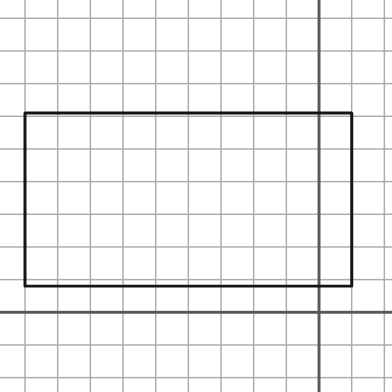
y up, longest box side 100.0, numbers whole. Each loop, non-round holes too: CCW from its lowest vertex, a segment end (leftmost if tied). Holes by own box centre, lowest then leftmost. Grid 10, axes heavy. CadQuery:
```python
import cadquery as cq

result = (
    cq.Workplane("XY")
    .moveTo(-90.0, 8.0)
    .lineTo(10.0, 8.0)
    .lineTo(10.0, 61.0)
    .lineTo(-90.0, 61.0)
    .close()
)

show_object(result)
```